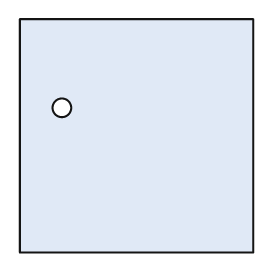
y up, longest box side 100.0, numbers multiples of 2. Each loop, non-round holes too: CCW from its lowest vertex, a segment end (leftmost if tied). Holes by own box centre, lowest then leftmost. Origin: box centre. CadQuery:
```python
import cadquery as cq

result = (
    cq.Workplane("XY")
    .moveTo(-50.0, -50.0)
    .lineTo(50.0, -50.0)
    .lineTo(50.0, 50.0)
    .lineTo(-50.0, 50.0)
    .close()
    .moveTo(-32.0, 12.0)
    .circle(4.0)
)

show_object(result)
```